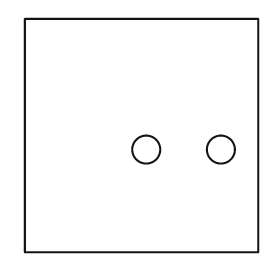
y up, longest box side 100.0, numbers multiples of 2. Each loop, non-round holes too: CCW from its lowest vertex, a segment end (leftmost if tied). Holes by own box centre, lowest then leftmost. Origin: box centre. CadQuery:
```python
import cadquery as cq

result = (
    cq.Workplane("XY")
    .moveTo(-50.0, -50.0)
    .lineTo(50.0, -50.0)
    .lineTo(50.0, 50.0)
    .lineTo(-50.0, 50.0)
    .close()
    .moveTo(2.0, -6.0)
    .circle(6.0)
    .moveTo(34.0, -6.0)
    .circle(6.0)
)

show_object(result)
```